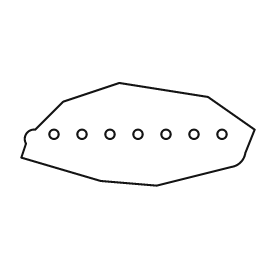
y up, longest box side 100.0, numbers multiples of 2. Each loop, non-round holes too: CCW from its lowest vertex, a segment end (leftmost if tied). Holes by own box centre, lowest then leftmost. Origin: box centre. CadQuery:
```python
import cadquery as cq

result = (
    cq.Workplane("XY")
    .moveTo(8.0, -22.0)
    .lineTo(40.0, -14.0)
    .threePointArc((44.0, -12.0), (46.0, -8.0))
    .lineTo(50.0, 2.0)
    .lineTo(30.0, 16.0)
    .lineTo(-8.0, 22.0)
    .lineTo(-32.0, 14.0)
    .lineTo(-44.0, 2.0)
    .threePointArc((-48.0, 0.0), (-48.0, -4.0))
    .lineTo(-50.0, -10.0)
    .lineTo(-16.0, -20.0)
    .close()
    .moveTo(-36.0, 0.0)
    .circle(2.0)
    .moveTo(-24.0, 0.0)
    .circle(2.0)
    .moveTo(-12.0, 0.0)
    .circle(2.0)
    .moveTo(0.0, 0.0)
    .circle(2.0)
    .moveTo(12.0, 0.0)
    .circle(2.0)
    .moveTo(24.0, 0.0)
    .circle(2.0)
    .moveTo(36.0, 0.0)
    .circle(2.0)
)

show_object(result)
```